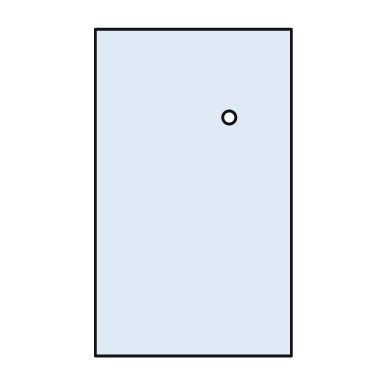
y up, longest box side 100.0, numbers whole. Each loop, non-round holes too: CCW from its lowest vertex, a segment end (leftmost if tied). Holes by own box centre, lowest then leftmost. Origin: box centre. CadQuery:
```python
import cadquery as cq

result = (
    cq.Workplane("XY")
    .moveTo(-30.0, -50.0)
    .lineTo(30.0, -50.0)
    .lineTo(30.0, 50.0)
    .lineTo(-30.0, 50.0)
    .close()
    .moveTo(11.0, 23.0)
    .circle(2.0)
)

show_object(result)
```